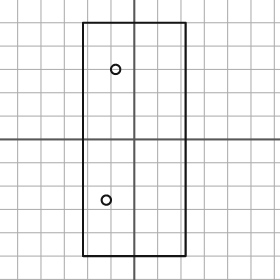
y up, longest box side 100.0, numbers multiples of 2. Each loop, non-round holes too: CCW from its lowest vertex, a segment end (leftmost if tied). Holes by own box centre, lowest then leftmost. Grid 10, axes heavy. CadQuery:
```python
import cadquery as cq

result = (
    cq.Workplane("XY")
    .moveTo(-22.0, -50.0)
    .lineTo(22.0, -50.0)
    .lineTo(22.0, 50.0)
    .lineTo(-22.0, 50.0)
    .close()
    .moveTo(-12.0, -26.0)
    .circle(2.0)
    .moveTo(-8.0, 30.0)
    .circle(2.0)
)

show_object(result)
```